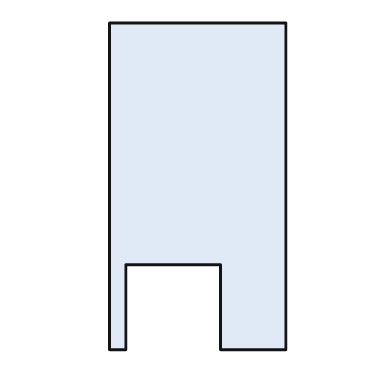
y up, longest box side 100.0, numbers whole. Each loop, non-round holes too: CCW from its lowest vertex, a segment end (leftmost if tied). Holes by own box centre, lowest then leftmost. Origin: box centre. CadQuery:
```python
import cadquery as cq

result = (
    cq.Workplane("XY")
    .moveTo(-27.0, -50.0)
    .lineTo(-22.0, -50.0)
    .lineTo(-22.0, -24.0)
    .lineTo(7.0, -24.0)
    .lineTo(7.0, -50.0)
    .lineTo(27.0, -50.0)
    .lineTo(27.0, 50.0)
    .lineTo(-27.0, 50.0)
    .close()
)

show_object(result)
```